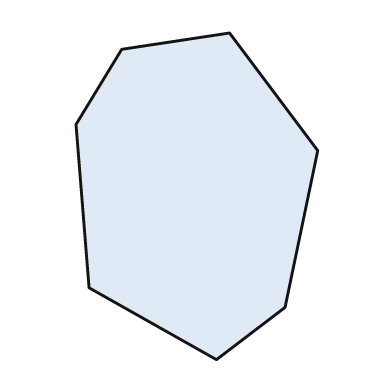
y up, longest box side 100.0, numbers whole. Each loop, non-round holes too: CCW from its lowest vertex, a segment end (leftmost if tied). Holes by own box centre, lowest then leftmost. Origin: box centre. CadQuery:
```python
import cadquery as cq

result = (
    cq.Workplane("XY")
    .moveTo(6.0, -50.0)
    .lineTo(27.0, -34.0)
    .lineTo(37.0, 14.0)
    .lineTo(10.0, 50.0)
    .lineTo(-23.0, 45.0)
    .lineTo(-37.0, 22.0)
    .lineTo(-33.0, -28.0)
    .close()
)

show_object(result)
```